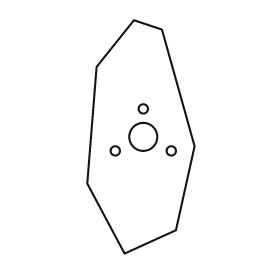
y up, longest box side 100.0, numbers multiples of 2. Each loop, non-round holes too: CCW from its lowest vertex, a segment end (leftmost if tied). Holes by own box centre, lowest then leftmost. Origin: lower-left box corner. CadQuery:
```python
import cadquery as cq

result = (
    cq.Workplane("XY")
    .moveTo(16.0, 0.0)
    .lineTo(38.0, 10.0)
    .lineTo(46.0, 46.0)
    .lineTo(32.0, 96.0)
    .lineTo(20.0, 100.0)
    .lineTo(4.0, 80.0)
    .lineTo(0.0, 30.0)
    .close()
    .moveTo(12.0, 44.0)
    .circle(2.0)
    .moveTo(36.0, 44.0)
    .circle(2.0)
    .moveTo(24.0, 50.0)
    .circle(6.0)
    .moveTo(24.0, 62.0)
    .circle(2.0)
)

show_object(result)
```